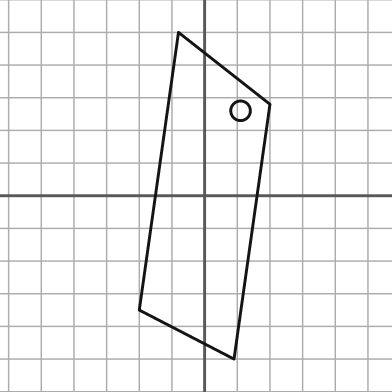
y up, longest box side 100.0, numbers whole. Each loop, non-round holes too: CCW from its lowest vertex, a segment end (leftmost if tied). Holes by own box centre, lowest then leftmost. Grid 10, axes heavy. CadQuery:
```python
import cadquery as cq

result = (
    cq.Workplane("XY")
    .moveTo(9.0, -50.0)
    .lineTo(20.0, 28.0)
    .lineTo(-8.0, 50.0)
    .lineTo(-20.0, -35.0)
    .close()
    .moveTo(11.0, 26.0)
    .circle(3.0)
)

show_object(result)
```